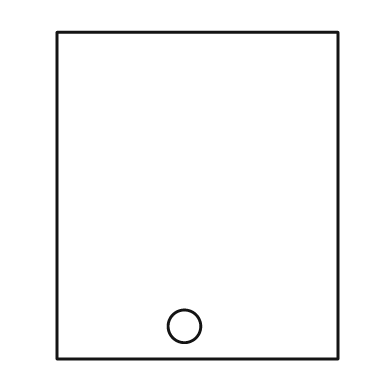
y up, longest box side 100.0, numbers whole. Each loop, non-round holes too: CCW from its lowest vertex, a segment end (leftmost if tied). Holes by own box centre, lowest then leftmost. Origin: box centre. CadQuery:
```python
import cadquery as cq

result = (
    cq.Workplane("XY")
    .moveTo(-43.0, -50.0)
    .lineTo(43.0, -50.0)
    .lineTo(43.0, 50.0)
    .lineTo(-43.0, 50.0)
    .close()
    .moveTo(-4.0, -40.0)
    .circle(5.0)
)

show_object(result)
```